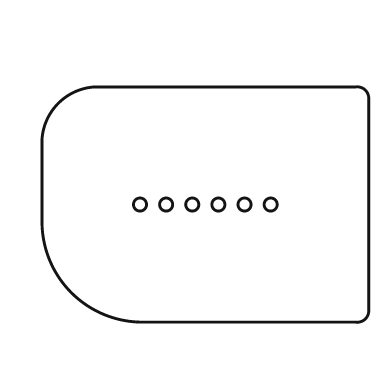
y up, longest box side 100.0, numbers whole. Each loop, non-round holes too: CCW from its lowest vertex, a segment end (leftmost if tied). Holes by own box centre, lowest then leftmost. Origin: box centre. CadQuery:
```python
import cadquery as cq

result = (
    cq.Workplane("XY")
    .moveTo(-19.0, -36.0)
    .lineTo(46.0, -36.0)
    .threePointArc((49.0, -35.0), (50.0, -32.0))
    .lineTo(50.0, 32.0)
    .threePointArc((49.0, 35.0), (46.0, 36.0))
    .lineTo(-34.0, 36.0)
    .threePointArc((-45.0, 31.0), (-50.0, 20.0))
    .lineTo(-50.0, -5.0)
    .threePointArc((-41.0, -27.0), (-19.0, -36.0))
    .close()
    .moveTo(-20.0, 0.0)
    .circle(2.0)
    .moveTo(-12.0, 0.0)
    .circle(2.0)
    .moveTo(-4.0, 0.0)
    .circle(2.0)
    .moveTo(4.0, 0.0)
    .circle(2.0)
    .moveTo(12.0, 0.0)
    .circle(2.0)
    .moveTo(20.0, 0.0)
    .circle(2.0)
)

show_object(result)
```